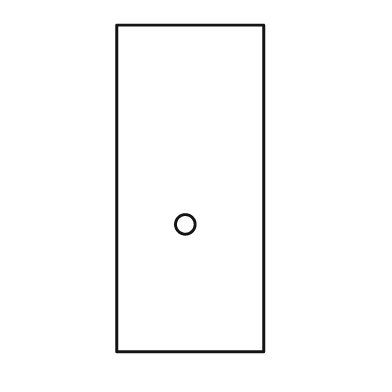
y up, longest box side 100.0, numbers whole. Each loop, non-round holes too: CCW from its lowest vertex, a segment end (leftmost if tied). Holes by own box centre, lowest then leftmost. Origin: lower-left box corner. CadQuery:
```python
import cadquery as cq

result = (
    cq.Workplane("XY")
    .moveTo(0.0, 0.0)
    .lineTo(45.0, 0.0)
    .lineTo(45.0, 100.0)
    .lineTo(0.0, 100.0)
    .close()
    .moveTo(21.0, 39.0)
    .circle(3.0)
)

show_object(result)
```